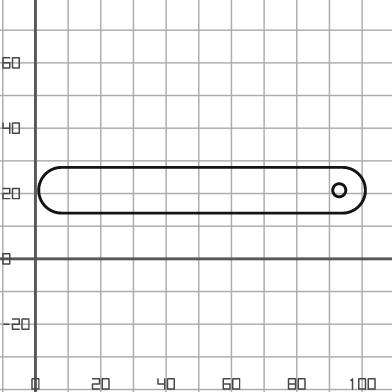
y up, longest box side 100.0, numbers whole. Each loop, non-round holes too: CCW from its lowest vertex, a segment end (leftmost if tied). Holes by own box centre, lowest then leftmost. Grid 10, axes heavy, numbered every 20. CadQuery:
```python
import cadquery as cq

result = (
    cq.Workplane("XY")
    .moveTo(8.0, 14.0)
    .lineTo(94.0, 14.0)
    .threePointArc((101.0, 21.0), (94.0, 28.0))
    .lineTo(8.0, 28.0)
    .threePointArc((1.0, 21.0), (8.0, 14.0))
    .close()
    .moveTo(93.0, 21.0)
    .circle(2.0)
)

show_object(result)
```